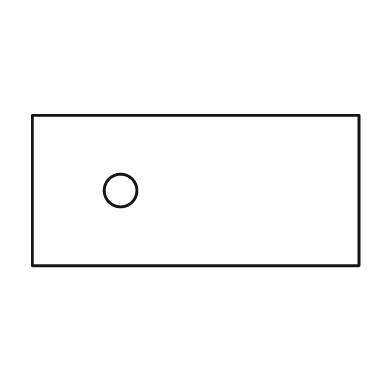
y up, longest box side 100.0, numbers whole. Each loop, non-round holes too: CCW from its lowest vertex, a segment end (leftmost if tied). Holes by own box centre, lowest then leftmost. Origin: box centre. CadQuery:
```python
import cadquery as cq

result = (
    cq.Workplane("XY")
    .moveTo(-50.0, -23.0)
    .lineTo(50.0, -23.0)
    .lineTo(50.0, 23.0)
    .lineTo(-50.0, 23.0)
    .close()
    .moveTo(-23.0, 0.0)
    .circle(5.0)
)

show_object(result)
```